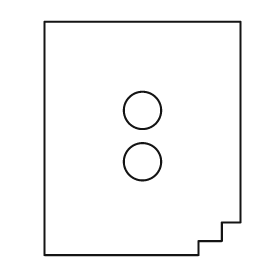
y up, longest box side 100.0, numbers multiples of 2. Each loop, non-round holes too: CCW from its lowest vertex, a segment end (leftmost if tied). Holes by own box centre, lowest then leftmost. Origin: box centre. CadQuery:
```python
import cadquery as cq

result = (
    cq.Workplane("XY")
    .moveTo(-42.0, -50.0)
    .lineTo(24.0, -50.0)
    .lineTo(24.0, -44.0)
    .lineTo(34.0, -44.0)
    .lineTo(34.0, -36.0)
    .lineTo(42.0, -36.0)
    .lineTo(42.0, 50.0)
    .lineTo(-42.0, 50.0)
    .close()
    .moveTo(0.0, -10.0)
    .circle(8.0)
    .moveTo(0.0, 12.0)
    .circle(8.0)
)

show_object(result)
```